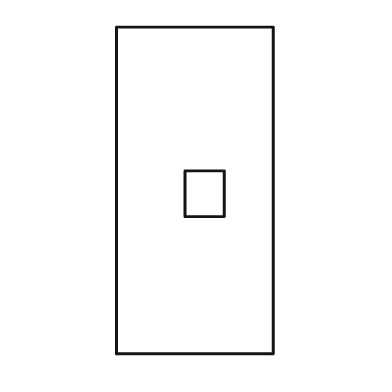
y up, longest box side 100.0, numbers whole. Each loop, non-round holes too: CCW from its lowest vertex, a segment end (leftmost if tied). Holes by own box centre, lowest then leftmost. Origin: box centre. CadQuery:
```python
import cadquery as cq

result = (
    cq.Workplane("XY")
    .moveTo(-24.0, -50.0)
    .lineTo(24.0, -50.0)
    .lineTo(24.0, 50.0)
    .lineTo(-24.0, 50.0)
    .close()
    .moveTo(-3.0, -8.0)
    .lineTo(9.0, -8.0)
    .lineTo(9.0, 6.0)
    .lineTo(-3.0, 6.0)
    .close()
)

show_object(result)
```